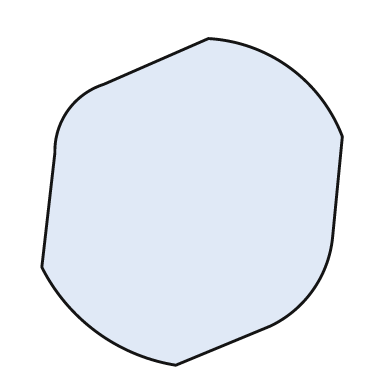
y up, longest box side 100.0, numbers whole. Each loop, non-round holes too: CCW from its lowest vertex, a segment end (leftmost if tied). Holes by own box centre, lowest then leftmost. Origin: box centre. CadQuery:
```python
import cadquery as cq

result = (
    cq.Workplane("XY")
    .moveTo(-5.0, -50.0)
    .lineTo(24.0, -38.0)
    .threePointArc((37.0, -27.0), (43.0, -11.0))
    .lineTo(46.0, 20.0)
    .threePointArc((30.0, 41.0), (5.0, 50.0))
    .lineTo(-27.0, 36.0)
    .threePointArc((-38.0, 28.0), (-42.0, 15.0))
    .lineTo(-46.0, -20.0)
    .threePointArc((-29.0, -40.0), (-5.0, -50.0))
    .close()
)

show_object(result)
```